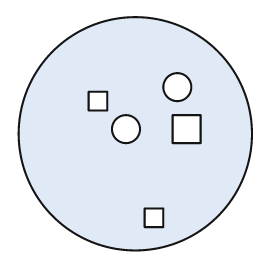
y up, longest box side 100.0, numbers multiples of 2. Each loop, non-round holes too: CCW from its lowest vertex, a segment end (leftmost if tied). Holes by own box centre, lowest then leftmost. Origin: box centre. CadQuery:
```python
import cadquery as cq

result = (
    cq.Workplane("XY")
    .moveTo(0.0, 0.0)
    .circle(50.0)
    .moveTo(4.0, -40.0)
    .lineTo(12.0, -40.0)
    .lineTo(12.0, -32.0)
    .lineTo(4.0, -32.0)
    .close()
    .moveTo(-4.0, 2.0)
    .circle(6.0)
    .moveTo(16.0, -4.0)
    .lineTo(28.0, -4.0)
    .lineTo(28.0, 8.0)
    .lineTo(16.0, 8.0)
    .close()
    .moveTo(-20.0, 10.0)
    .lineTo(-12.0, 10.0)
    .lineTo(-12.0, 18.0)
    .lineTo(-20.0, 18.0)
    .close()
    .moveTo(18.0, 20.0)
    .circle(6.0)
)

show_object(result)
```